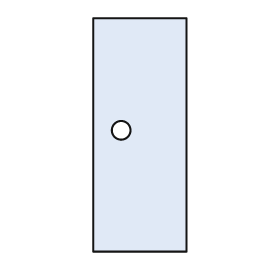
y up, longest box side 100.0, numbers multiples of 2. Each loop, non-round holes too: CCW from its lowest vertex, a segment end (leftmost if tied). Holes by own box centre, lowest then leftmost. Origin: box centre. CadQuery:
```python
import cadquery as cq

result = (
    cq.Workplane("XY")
    .moveTo(-20.0, -50.0)
    .lineTo(20.0, -50.0)
    .lineTo(20.0, 50.0)
    .lineTo(-20.0, 50.0)
    .close()
    .moveTo(-8.0, 2.0)
    .circle(4.0)
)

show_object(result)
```